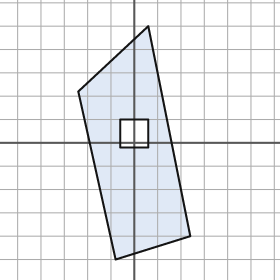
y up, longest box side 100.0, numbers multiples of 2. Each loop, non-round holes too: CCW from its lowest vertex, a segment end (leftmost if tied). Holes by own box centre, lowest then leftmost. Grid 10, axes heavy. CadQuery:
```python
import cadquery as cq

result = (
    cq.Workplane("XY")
    .moveTo(-8.0, -50.0)
    .lineTo(24.0, -40.0)
    .lineTo(6.0, 50.0)
    .lineTo(-24.0, 22.0)
    .close()
    .moveTo(-6.0, -2.0)
    .lineTo(6.0, -2.0)
    .lineTo(6.0, 10.0)
    .lineTo(-6.0, 10.0)
    .close()
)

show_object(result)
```